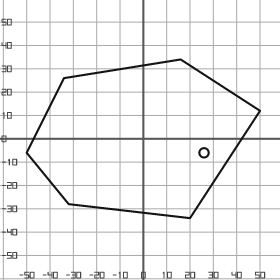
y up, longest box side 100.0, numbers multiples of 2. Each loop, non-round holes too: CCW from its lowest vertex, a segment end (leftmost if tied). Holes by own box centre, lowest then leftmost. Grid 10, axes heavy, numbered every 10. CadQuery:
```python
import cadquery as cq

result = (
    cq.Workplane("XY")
    .moveTo(20.0, -34.0)
    .lineTo(50.0, 12.0)
    .lineTo(16.0, 34.0)
    .lineTo(-34.0, 26.0)
    .lineTo(-50.0, -6.0)
    .lineTo(-32.0, -28.0)
    .close()
    .moveTo(26.0, -6.0)
    .circle(2.0)
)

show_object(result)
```